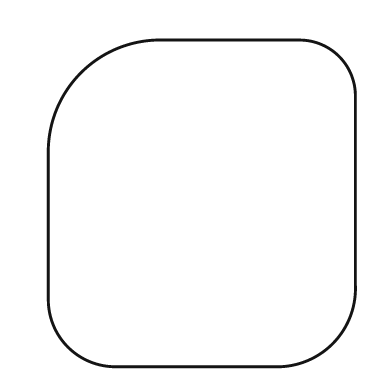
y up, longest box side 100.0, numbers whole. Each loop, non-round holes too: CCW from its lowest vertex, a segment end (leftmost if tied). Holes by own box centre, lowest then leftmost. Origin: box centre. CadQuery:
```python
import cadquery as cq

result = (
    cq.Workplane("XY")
    .moveTo(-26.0, -50.0)
    .lineTo(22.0, -50.0)
    .threePointArc((40.0, -43.0), (47.0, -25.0))
    .lineTo(47.0, 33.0)
    .threePointArc((42.0, 45.0), (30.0, 50.0))
    .lineTo(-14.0, 50.0)
    .threePointArc((-37.0, 40.0), (-47.0, 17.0))
    .lineTo(-47.0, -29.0)
    .threePointArc((-41.0, -44.0), (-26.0, -50.0))
    .close()
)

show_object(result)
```